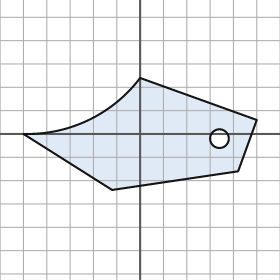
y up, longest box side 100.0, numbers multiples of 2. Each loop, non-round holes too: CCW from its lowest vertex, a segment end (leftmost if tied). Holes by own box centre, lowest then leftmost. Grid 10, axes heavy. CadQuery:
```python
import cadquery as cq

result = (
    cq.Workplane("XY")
    .moveTo(-12.0, -24.0)
    .lineTo(42.0, -16.0)
    .lineTo(50.0, 6.0)
    .lineTo(0.0, 24.0)
    .threePointArc((-22.0, 6.0), (-50.0, 0.0))
    .close()
    .moveTo(34.0, -2.0)
    .circle(4.0)
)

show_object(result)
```